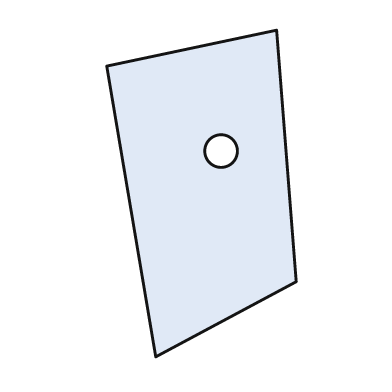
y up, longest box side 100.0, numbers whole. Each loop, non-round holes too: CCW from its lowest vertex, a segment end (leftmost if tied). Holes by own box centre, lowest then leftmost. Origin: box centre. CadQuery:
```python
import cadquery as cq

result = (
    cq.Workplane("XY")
    .moveTo(-14.0, -50.0)
    .lineTo(29.0, -27.0)
    .lineTo(23.0, 50.0)
    .lineTo(-29.0, 39.0)
    .close()
    .moveTo(6.0, 13.0)
    .circle(5.0)
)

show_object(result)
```